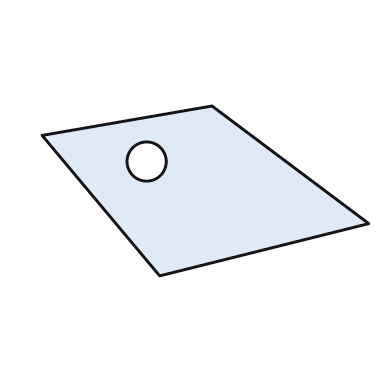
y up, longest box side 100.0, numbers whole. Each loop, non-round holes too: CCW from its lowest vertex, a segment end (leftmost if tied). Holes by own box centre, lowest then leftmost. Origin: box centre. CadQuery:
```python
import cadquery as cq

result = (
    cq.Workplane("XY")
    .moveTo(-14.0, -26.0)
    .lineTo(50.0, -10.0)
    .lineTo(2.0, 26.0)
    .lineTo(-50.0, 17.0)
    .close()
    .moveTo(-18.0, 9.0)
    .circle(6.0)
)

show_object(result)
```